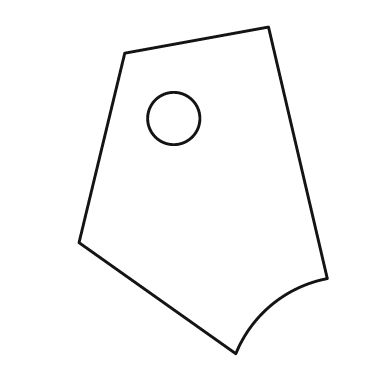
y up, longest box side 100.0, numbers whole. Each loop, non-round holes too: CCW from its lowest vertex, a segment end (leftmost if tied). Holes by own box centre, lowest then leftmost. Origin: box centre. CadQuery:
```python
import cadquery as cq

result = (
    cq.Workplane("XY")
    .moveTo(10.0, -50.0)
    .threePointArc((21.0, -35.0), (38.0, -27.0))
    .lineTo(20.0, 50.0)
    .lineTo(-24.0, 42.0)
    .lineTo(-38.0, -16.0)
    .close()
    .moveTo(-9.0, 22.0)
    .circle(8.0)
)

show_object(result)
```